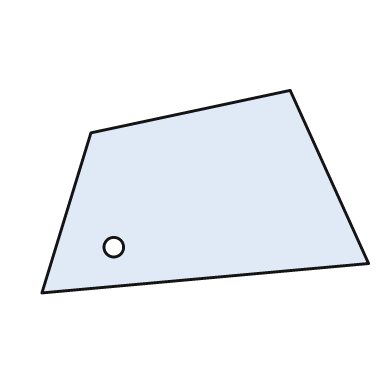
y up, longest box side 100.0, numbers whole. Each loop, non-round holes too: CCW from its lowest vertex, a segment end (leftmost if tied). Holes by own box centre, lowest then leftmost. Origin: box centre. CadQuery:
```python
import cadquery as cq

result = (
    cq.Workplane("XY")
    .moveTo(-50.0, -31.0)
    .lineTo(50.0, -22.0)
    .lineTo(26.0, 31.0)
    .lineTo(-35.0, 18.0)
    .close()
    .moveTo(-28.0, -17.0)
    .circle(3.0)
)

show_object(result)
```